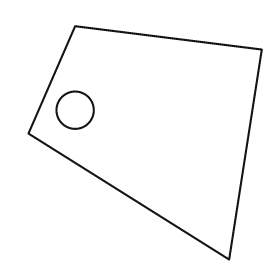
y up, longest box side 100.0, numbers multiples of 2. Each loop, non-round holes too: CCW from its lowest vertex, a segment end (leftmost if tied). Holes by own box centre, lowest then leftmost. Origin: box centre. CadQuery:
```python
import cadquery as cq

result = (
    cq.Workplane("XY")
    .moveTo(36.0, -50.0)
    .lineTo(50.0, 40.0)
    .lineTo(-30.0, 50.0)
    .lineTo(-50.0, 4.0)
    .close()
    .moveTo(-30.0, 14.0)
    .circle(8.0)
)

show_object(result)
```